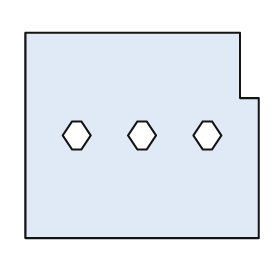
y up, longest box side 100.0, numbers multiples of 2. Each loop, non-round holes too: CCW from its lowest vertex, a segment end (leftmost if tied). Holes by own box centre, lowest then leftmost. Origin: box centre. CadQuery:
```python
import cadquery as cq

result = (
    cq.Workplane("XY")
    .moveTo(-50.0, -44.0)
    .lineTo(50.0, -44.0)
    .lineTo(50.0, 16.0)
    .lineTo(42.0, 16.0)
    .lineTo(42.0, 44.0)
    .lineTo(-50.0, 44.0)
    .close()
    .moveTo(-30.0, -6.0)
    .lineTo(-26.0, -6.0)
    .lineTo(-22.0, 0.0)
    .lineTo(-26.0, 6.0)
    .lineTo(-30.0, 6.0)
    .lineTo(-34.0, 0.0)
    .close()
    .moveTo(-2.0, -6.0)
    .lineTo(2.0, -6.0)
    .lineTo(6.0, 0.0)
    .lineTo(2.0, 6.0)
    .lineTo(-2.0, 6.0)
    .lineTo(-6.0, 0.0)
    .close()
    .moveTo(26.0, -6.0)
    .lineTo(30.0, -6.0)
    .lineTo(34.0, 0.0)
    .lineTo(30.0, 6.0)
    .lineTo(26.0, 6.0)
    .lineTo(22.0, 0.0)
    .close()
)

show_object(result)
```